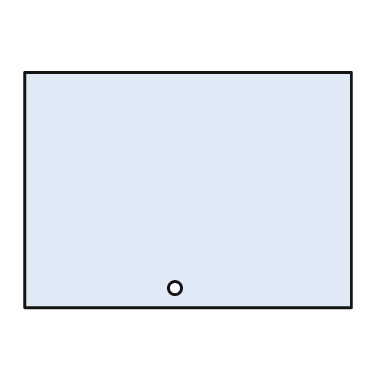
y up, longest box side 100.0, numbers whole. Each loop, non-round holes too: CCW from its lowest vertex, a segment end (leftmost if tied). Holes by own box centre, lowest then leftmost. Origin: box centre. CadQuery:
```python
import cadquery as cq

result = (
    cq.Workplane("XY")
    .moveTo(-50.0, -36.0)
    .lineTo(50.0, -36.0)
    .lineTo(50.0, 36.0)
    .lineTo(-50.0, 36.0)
    .close()
    .moveTo(-4.0, -30.0)
    .circle(2.0)
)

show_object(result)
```